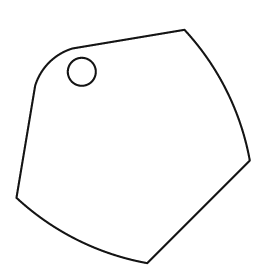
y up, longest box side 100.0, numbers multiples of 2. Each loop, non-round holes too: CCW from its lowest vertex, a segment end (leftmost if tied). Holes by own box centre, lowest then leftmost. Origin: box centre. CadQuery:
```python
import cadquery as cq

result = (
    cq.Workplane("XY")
    .moveTo(6.0, -50.0)
    .lineTo(50.0, -6.0)
    .threePointArc((40.0, 24.0), (22.0, 50.0))
    .lineTo(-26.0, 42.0)
    .threePointArc((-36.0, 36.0), (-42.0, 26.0))
    .lineTo(-50.0, -22.0)
    .threePointArc((-24.0, -40.0), (6.0, -50.0))
    .close()
    .moveTo(-22.0, 32.0)
    .circle(6.0)
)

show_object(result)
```